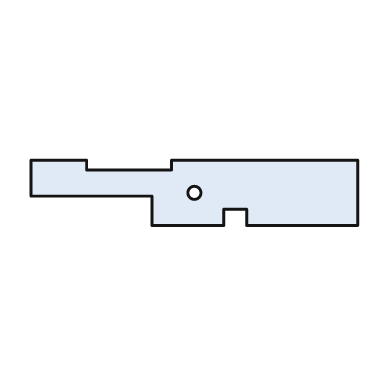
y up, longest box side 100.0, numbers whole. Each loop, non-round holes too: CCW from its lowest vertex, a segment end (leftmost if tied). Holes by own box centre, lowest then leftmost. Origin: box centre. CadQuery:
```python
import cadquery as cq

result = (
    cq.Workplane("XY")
    .moveTo(-13.0, -10.0)
    .lineTo(9.0, -10.0)
    .lineTo(9.0, -5.0)
    .lineTo(16.0, -5.0)
    .lineTo(16.0, -10.0)
    .lineTo(50.0, -10.0)
    .lineTo(50.0, 10.0)
    .lineTo(-7.0, 10.0)
    .lineTo(-7.0, 7.0)
    .lineTo(-33.0, 7.0)
    .lineTo(-33.0, 10.0)
    .lineTo(-50.0, 10.0)
    .lineTo(-50.0, -1.0)
    .lineTo(-13.0, -1.0)
    .close()
    .moveTo(0.0, 0.0)
    .circle(2.0)
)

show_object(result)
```